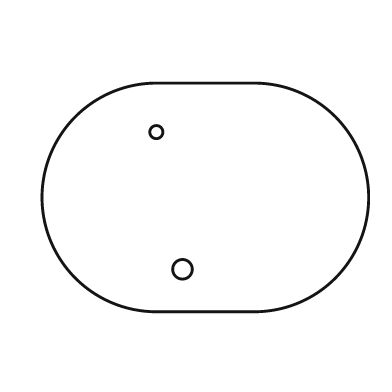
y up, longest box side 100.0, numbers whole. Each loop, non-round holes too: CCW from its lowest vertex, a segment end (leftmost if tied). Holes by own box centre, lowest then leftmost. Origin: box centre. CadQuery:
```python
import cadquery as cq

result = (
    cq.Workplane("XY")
    .moveTo(-15.0, -35.0)
    .lineTo(15.0, -35.0)
    .threePointArc((50.0, 0.0), (15.0, 35.0))
    .lineTo(-15.0, 35.0)
    .threePointArc((-50.0, 0.0), (-15.0, -35.0))
    .close()
    .moveTo(-7.0, -22.0)
    .circle(3.0)
    .moveTo(-15.0, 20.0)
    .circle(2.0)
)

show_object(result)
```